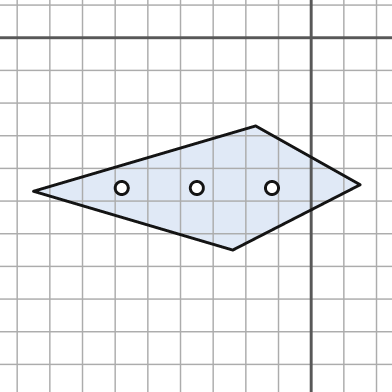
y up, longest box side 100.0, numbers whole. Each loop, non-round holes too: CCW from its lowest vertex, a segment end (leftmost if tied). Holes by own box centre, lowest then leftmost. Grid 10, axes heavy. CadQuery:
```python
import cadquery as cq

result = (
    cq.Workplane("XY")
    .moveTo(-24.0, -65.0)
    .lineTo(15.0, -45.0)
    .lineTo(-17.0, -27.0)
    .lineTo(-85.0, -47.0)
    .close()
    .moveTo(-58.0, -46.0)
    .circle(2.0)
    .moveTo(-35.0, -46.0)
    .circle(2.0)
    .moveTo(-12.0, -46.0)
    .circle(2.0)
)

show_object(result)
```